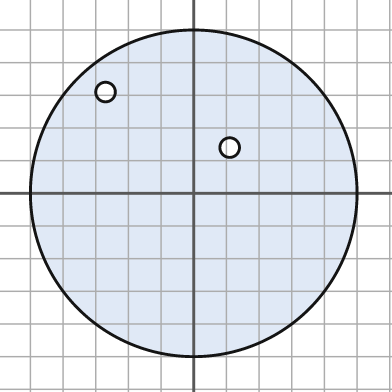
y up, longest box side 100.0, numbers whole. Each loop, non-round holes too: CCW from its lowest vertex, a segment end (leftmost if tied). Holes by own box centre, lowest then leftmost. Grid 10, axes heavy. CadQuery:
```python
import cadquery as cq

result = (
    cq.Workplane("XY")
    .moveTo(0.0, 0.0)
    .circle(50.0)
    .moveTo(11.0, 14.0)
    .circle(3.0)
    .moveTo(-27.0, 31.0)
    .circle(3.0)
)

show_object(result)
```